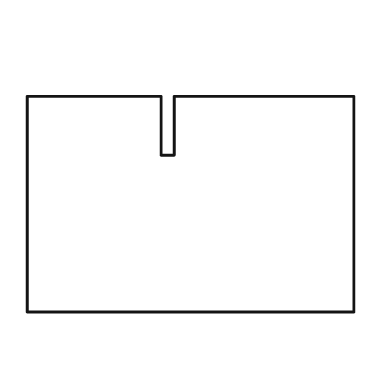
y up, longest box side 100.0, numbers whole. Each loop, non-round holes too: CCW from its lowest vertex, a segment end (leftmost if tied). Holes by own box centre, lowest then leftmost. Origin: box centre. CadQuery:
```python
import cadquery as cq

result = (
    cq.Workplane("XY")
    .moveTo(-50.0, -33.0)
    .lineTo(50.0, -33.0)
    .lineTo(50.0, 33.0)
    .lineTo(-5.0, 33.0)
    .lineTo(-5.0, 15.0)
    .lineTo(-9.0, 15.0)
    .lineTo(-9.0, 33.0)
    .lineTo(-50.0, 33.0)
    .close()
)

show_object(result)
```